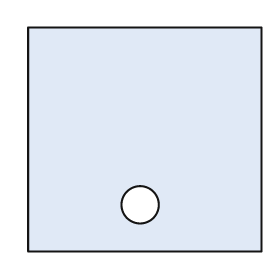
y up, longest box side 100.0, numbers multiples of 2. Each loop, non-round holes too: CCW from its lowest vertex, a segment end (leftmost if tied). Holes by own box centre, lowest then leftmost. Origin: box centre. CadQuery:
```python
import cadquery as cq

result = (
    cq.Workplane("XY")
    .moveTo(-50.0, -48.0)
    .lineTo(50.0, -48.0)
    .lineTo(50.0, 48.0)
    .lineTo(-50.0, 48.0)
    .close()
    .moveTo(-2.0, -28.0)
    .circle(8.0)
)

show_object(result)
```